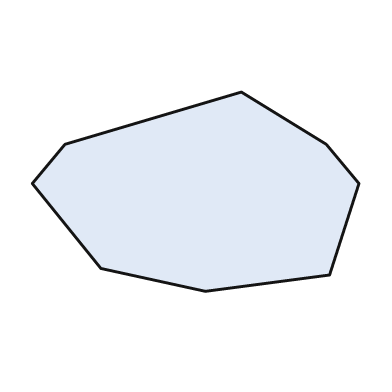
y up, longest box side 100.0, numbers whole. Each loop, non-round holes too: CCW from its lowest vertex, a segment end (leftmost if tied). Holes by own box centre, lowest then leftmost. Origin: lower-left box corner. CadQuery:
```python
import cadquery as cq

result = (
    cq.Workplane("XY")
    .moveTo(53.0, 0.0)
    .lineTo(91.0, 5.0)
    .lineTo(100.0, 33.0)
    .lineTo(90.0, 45.0)
    .lineTo(64.0, 61.0)
    .lineTo(10.0, 45.0)
    .lineTo(0.0, 33.0)
    .lineTo(21.0, 7.0)
    .close()
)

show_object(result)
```